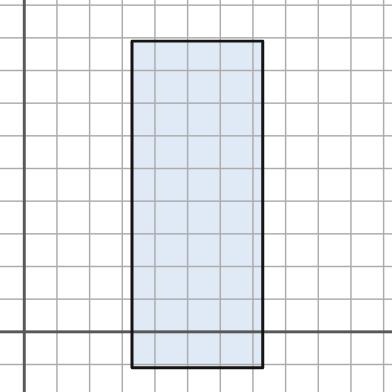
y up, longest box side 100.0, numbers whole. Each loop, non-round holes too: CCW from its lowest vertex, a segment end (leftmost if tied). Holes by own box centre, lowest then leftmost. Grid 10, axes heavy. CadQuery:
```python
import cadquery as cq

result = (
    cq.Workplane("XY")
    .moveTo(33.0, -11.0)
    .lineTo(73.0, -11.0)
    .lineTo(73.0, 89.0)
    .lineTo(33.0, 89.0)
    .close()
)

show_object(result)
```